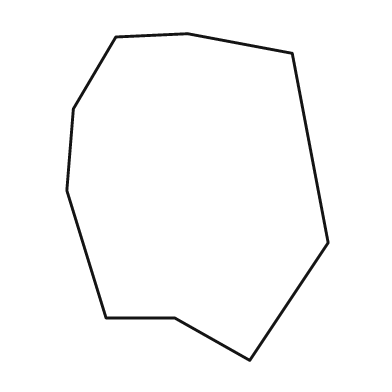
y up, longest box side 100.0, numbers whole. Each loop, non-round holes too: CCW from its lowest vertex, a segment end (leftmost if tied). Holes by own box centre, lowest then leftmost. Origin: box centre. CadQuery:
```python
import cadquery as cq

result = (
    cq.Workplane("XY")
    .moveTo(16.0, -50.0)
    .lineTo(40.0, -14.0)
    .lineTo(29.0, 44.0)
    .lineTo(-3.0, 50.0)
    .lineTo(-25.0, 49.0)
    .lineTo(-38.0, 27.0)
    .lineTo(-40.0, 2.0)
    .lineTo(-28.0, -37.0)
    .lineTo(-7.0, -37.0)
    .close()
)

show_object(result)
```